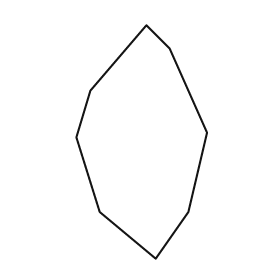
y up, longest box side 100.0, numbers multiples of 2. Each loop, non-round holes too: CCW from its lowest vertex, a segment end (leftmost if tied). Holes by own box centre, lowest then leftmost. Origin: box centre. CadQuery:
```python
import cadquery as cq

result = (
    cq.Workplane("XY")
    .moveTo(6.0, -50.0)
    .lineTo(20.0, -30.0)
    .lineTo(28.0, 4.0)
    .lineTo(12.0, 40.0)
    .lineTo(2.0, 50.0)
    .lineTo(-22.0, 22.0)
    .lineTo(-28.0, 2.0)
    .lineTo(-18.0, -30.0)
    .close()
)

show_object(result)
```